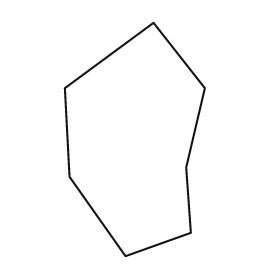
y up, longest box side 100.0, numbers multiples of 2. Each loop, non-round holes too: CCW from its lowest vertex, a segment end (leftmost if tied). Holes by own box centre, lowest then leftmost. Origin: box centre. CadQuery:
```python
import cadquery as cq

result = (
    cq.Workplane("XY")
    .moveTo(-4.0, -50.0)
    .lineTo(24.0, -40.0)
    .lineTo(22.0, -12.0)
    .lineTo(30.0, 22.0)
    .lineTo(8.0, 50.0)
    .lineTo(-30.0, 22.0)
    .lineTo(-28.0, -16.0)
    .close()
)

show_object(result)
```